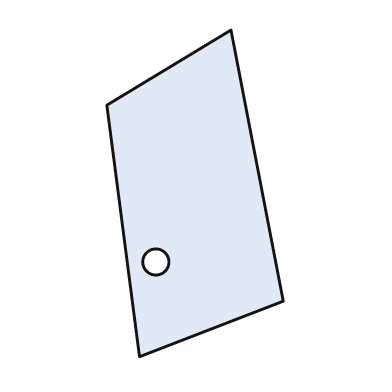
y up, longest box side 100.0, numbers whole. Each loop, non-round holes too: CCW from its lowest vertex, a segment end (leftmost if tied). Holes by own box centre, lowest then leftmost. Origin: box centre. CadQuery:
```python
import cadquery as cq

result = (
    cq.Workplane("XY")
    .moveTo(-17.0, -50.0)
    .lineTo(27.0, -33.0)
    .lineTo(11.0, 50.0)
    .lineTo(-27.0, 27.0)
    .close()
    .moveTo(-12.0, -21.0)
    .circle(4.0)
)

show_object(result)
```